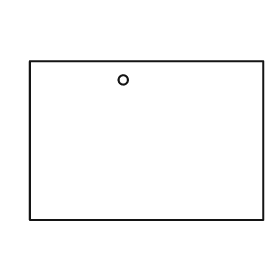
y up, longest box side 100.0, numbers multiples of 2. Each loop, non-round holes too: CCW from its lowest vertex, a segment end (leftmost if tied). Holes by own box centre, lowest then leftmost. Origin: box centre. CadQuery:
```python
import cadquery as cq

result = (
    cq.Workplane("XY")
    .moveTo(-50.0, -34.0)
    .lineTo(50.0, -34.0)
    .lineTo(50.0, 34.0)
    .lineTo(-50.0, 34.0)
    .close()
    .moveTo(-10.0, 26.0)
    .circle(2.0)
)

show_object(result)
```